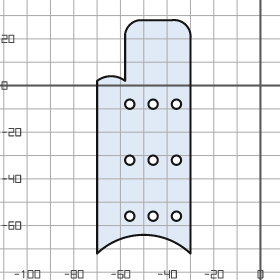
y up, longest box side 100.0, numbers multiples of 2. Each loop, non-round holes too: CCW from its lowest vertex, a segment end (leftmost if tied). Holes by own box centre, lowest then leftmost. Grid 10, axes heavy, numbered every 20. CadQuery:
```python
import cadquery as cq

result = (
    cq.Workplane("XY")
    .moveTo(-70.0, -72.0)
    .threePointArc((-50.0, -64.0), (-30.0, -72.0))
    .lineTo(-30.0, 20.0)
    .threePointArc((-32.0, 26.0), (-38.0, 28.0))
    .lineTo(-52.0, 28.0)
    .threePointArc((-56.0, 26.0), (-58.0, 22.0))
    .lineTo(-58.0, 2.0)
    .threePointArc((-64.0, 4.0), (-70.0, 2.0))
    .close()
    .moveTo(-56.0, -56.0)
    .circle(2.0)
    .moveTo(-46.0, -56.0)
    .circle(2.0)
    .moveTo(-36.0, -56.0)
    .circle(2.0)
    .moveTo(-56.0, -32.0)
    .circle(2.0)
    .moveTo(-46.0, -32.0)
    .circle(2.0)
    .moveTo(-36.0, -32.0)
    .circle(2.0)
    .moveTo(-56.0, -8.0)
    .circle(2.0)
    .moveTo(-46.0, -8.0)
    .circle(2.0)
    .moveTo(-36.0, -8.0)
    .circle(2.0)
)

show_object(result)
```